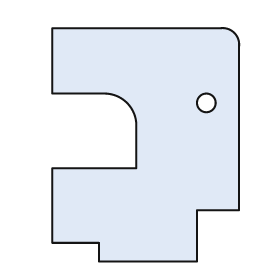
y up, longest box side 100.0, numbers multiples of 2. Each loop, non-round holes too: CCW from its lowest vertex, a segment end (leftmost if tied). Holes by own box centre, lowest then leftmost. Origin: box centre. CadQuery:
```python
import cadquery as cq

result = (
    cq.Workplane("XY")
    .moveTo(-20.0, -50.0)
    .lineTo(22.0, -50.0)
    .lineTo(22.0, -28.0)
    .lineTo(40.0, -28.0)
    .lineTo(40.0, 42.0)
    .threePointArc((38.0, 48.0), (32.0, 50.0))
    .lineTo(-40.0, 50.0)
    .lineTo(-40.0, 22.0)
    .lineTo(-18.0, 22.0)
    .threePointArc((-8.0, 18.0), (-4.0, 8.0))
    .lineTo(-4.0, -10.0)
    .lineTo(-40.0, -10.0)
    .lineTo(-40.0, -42.0)
    .lineTo(-20.0, -42.0)
    .close()
    .moveTo(26.0, 18.0)
    .circle(4.0)
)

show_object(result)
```